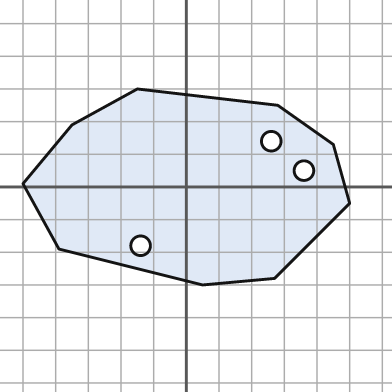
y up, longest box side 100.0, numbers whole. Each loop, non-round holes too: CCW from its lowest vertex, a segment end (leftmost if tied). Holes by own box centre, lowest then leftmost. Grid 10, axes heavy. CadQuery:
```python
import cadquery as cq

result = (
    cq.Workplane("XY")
    .moveTo(5.0, -30.0)
    .lineTo(27.0, -28.0)
    .lineTo(50.0, -5.0)
    .lineTo(45.0, 13.0)
    .lineTo(28.0, 25.0)
    .lineTo(-15.0, 30.0)
    .lineTo(-35.0, 19.0)
    .lineTo(-50.0, 1.0)
    .lineTo(-39.0, -19.0)
    .close()
    .moveTo(-14.0, -18.0)
    .circle(3.0)
    .moveTo(36.0, 5.0)
    .circle(3.0)
    .moveTo(26.0, 14.0)
    .circle(3.0)
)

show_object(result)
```